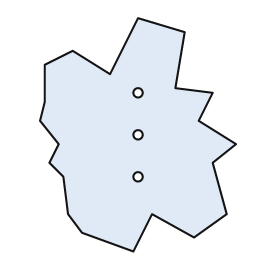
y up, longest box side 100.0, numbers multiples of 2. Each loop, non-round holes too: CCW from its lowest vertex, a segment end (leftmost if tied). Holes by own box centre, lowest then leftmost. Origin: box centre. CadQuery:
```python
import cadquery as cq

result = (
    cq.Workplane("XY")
    .moveTo(-2.0, -50.0)
    .lineTo(6.0, -34.0)
    .lineTo(24.0, -44.0)
    .lineTo(38.0, -34.0)
    .lineTo(32.0, -12.0)
    .lineTo(42.0, -4.0)
    .lineTo(26.0, 6.0)
    .lineTo(32.0, 18.0)
    .lineTo(16.0, 20.0)
    .lineTo(20.0, 44.0)
    .lineTo(0.0, 50.0)
    .lineTo(-12.0, 26.0)
    .lineTo(-28.0, 36.0)
    .lineTo(-40.0, 30.0)
    .lineTo(-40.0, 14.0)
    .lineTo(-42.0, 6.0)
    .lineTo(-34.0, -4.0)
    .lineTo(-38.0, -12.0)
    .lineTo(-32.0, -18.0)
    .lineTo(-30.0, -34.0)
    .lineTo(-24.0, -42.0)
    .close()
    .moveTo(0.0, -18.0)
    .circle(2.0)
    .moveTo(0.0, 0.0)
    .circle(2.0)
    .moveTo(0.0, 18.0)
    .circle(2.0)
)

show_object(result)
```